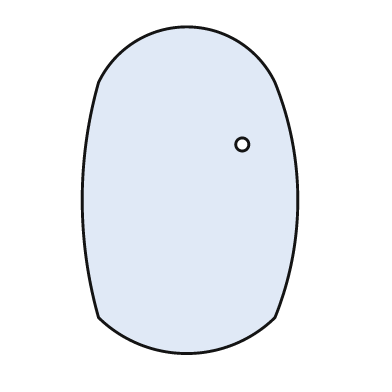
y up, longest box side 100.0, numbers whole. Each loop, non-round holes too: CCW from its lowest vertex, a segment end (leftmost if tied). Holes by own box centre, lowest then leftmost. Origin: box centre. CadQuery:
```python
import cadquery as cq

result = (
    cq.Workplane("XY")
    .moveTo(-28.0, -39.0)
    .threePointArc((-1.0, -50.0), (26.0, -39.0))
    .threePointArc((33.0, -3.0), (26.0, 33.0))
    .threePointArc((-1.0, 50.0), (-28.0, 33.0))
    .threePointArc((-33.0, -3.0), (-28.0, -39.0))
    .close()
    .moveTo(16.0, 14.0)
    .circle(2.0)
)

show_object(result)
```